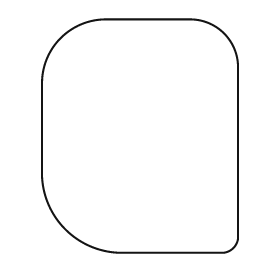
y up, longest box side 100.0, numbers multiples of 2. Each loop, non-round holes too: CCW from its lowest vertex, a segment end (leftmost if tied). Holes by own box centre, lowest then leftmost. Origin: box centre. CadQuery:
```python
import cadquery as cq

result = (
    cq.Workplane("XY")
    .moveTo(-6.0, -50.0)
    .lineTo(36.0, -50.0)
    .threePointArc((40.0, -48.0), (42.0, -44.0))
    .lineTo(42.0, 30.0)
    .threePointArc((36.0, 44.0), (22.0, 50.0))
    .lineTo(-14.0, 50.0)
    .threePointArc((-34.0, 42.0), (-42.0, 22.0))
    .lineTo(-42.0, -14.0)
    .threePointArc((-32.0, -40.0), (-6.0, -50.0))
    .close()
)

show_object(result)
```